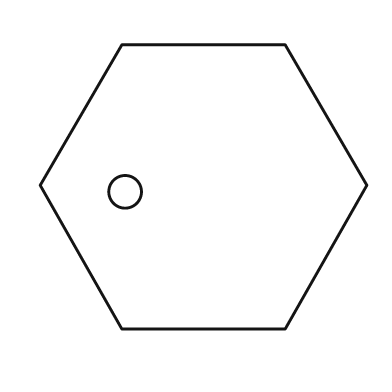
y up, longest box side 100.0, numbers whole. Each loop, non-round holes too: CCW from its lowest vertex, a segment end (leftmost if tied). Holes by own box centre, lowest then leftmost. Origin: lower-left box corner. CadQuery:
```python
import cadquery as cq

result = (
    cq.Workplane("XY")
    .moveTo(25.0, 0.0)
    .lineTo(75.0, 0.0)
    .lineTo(100.0, 44.0)
    .lineTo(75.0, 87.0)
    .lineTo(25.0, 87.0)
    .lineTo(0.0, 44.0)
    .close()
    .moveTo(26.0, 42.0)
    .circle(5.0)
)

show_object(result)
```